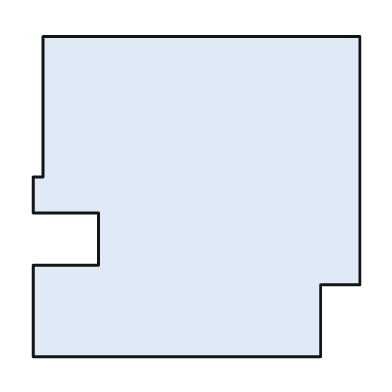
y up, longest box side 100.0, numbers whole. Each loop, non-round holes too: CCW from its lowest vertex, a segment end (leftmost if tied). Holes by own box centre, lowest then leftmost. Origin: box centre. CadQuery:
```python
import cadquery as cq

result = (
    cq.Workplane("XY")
    .moveTo(-50.0, -49.0)
    .lineTo(38.0, -49.0)
    .lineTo(38.0, -27.0)
    .lineTo(50.0, -27.0)
    .lineTo(50.0, 49.0)
    .lineTo(-47.0, 49.0)
    .lineTo(-47.0, 6.0)
    .lineTo(-50.0, 6.0)
    .lineTo(-50.0, -5.0)
    .lineTo(-30.0, -5.0)
    .lineTo(-30.0, -21.0)
    .lineTo(-50.0, -21.0)
    .close()
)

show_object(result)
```